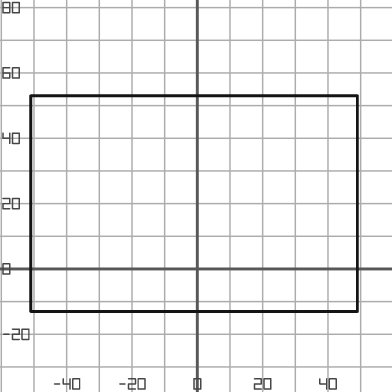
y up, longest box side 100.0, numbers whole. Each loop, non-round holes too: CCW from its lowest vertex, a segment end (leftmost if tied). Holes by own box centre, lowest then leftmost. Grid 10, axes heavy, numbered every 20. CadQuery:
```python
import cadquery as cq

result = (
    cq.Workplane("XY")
    .moveTo(-51.0, -13.0)
    .lineTo(49.0, -13.0)
    .lineTo(49.0, 53.0)
    .lineTo(-51.0, 53.0)
    .close()
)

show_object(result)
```